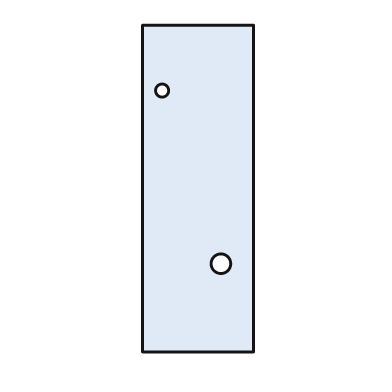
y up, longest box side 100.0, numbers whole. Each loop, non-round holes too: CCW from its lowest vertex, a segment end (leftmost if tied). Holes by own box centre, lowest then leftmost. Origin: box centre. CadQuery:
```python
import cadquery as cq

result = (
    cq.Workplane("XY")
    .moveTo(-17.0, -50.0)
    .lineTo(17.0, -50.0)
    .lineTo(17.0, 50.0)
    .lineTo(-17.0, 50.0)
    .close()
    .moveTo(7.0, -23.0)
    .circle(3.0)
    .moveTo(-11.0, 30.0)
    .circle(2.0)
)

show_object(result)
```